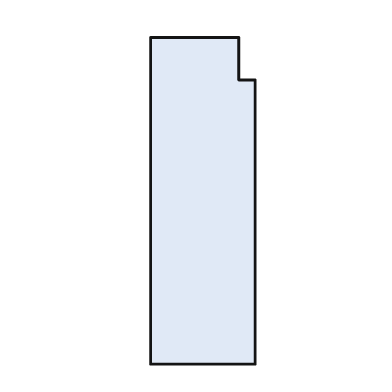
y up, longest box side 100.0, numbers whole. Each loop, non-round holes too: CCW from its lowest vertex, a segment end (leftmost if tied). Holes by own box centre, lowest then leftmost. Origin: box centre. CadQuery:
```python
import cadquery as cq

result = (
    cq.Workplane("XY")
    .moveTo(-16.0, -50.0)
    .lineTo(16.0, -50.0)
    .lineTo(16.0, 37.0)
    .lineTo(11.0, 37.0)
    .lineTo(11.0, 50.0)
    .lineTo(-16.0, 50.0)
    .close()
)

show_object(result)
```